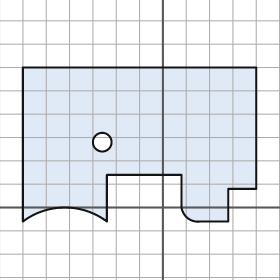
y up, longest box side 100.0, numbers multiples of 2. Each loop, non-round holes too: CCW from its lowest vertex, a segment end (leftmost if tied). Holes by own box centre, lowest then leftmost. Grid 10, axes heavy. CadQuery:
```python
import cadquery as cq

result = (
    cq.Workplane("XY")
    .moveTo(-60.0, -6.0)
    .threePointArc((-42.0, 0.0), (-24.0, -6.0))
    .lineTo(-24.0, 14.0)
    .lineTo(8.0, 14.0)
    .lineTo(8.0, 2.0)
    .threePointArc((10.0, -4.0), (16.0, -6.0))
    .lineTo(28.0, -6.0)
    .lineTo(28.0, 8.0)
    .lineTo(40.0, 8.0)
    .lineTo(40.0, 60.0)
    .lineTo(-60.0, 60.0)
    .close()
    .moveTo(-26.0, 28.0)
    .circle(4.0)
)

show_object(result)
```